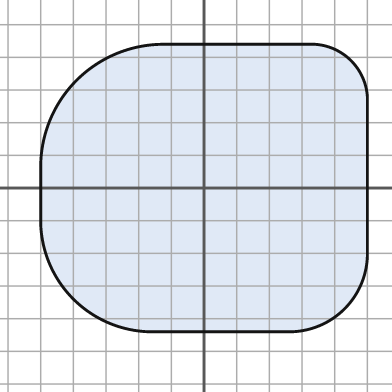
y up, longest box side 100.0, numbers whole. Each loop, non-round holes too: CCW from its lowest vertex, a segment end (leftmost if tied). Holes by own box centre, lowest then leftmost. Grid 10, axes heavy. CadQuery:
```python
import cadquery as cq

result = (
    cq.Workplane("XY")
    .moveTo(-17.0, -44.0)
    .lineTo(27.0, -44.0)
    .threePointArc((43.0, -37.0), (50.0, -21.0))
    .lineTo(50.0, 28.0)
    .threePointArc((45.0, 39.0), (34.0, 44.0))
    .lineTo(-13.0, 44.0)
    .threePointArc((-39.0, 33.0), (-50.0, 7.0))
    .lineTo(-50.0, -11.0)
    .threePointArc((-40.0, -34.0), (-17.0, -44.0))
    .close()
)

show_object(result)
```